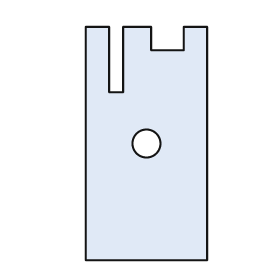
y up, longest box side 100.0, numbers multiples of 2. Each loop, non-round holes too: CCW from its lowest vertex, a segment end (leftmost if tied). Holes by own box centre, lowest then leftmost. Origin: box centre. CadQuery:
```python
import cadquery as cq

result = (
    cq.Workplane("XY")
    .moveTo(-26.0, -50.0)
    .lineTo(26.0, -50.0)
    .lineTo(26.0, 50.0)
    .lineTo(16.0, 50.0)
    .lineTo(16.0, 40.0)
    .lineTo(2.0, 40.0)
    .lineTo(2.0, 50.0)
    .lineTo(-10.0, 50.0)
    .lineTo(-10.0, 22.0)
    .lineTo(-16.0, 22.0)
    .lineTo(-16.0, 50.0)
    .lineTo(-26.0, 50.0)
    .close()
    .moveTo(0.0, 0.0)
    .circle(6.0)
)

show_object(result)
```